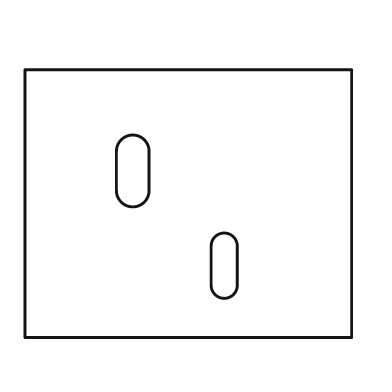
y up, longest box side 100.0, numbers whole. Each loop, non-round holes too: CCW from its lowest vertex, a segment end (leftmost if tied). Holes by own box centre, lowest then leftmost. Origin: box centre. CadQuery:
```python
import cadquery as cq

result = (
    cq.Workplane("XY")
    .moveTo(-50.0, -41.0)
    .lineTo(50.0, -41.0)
    .lineTo(50.0, 41.0)
    .lineTo(-50.0, 41.0)
    .close()
    .moveTo(7.0, -25.0)
    .threePointArc((11.0, -29.0), (15.0, -25.0))
    .lineTo(15.0, -13.0)
    .threePointArc((11.0, -9.0), (7.0, -13.0))
    .close()
    .moveTo(-22.0, 4.0)
    .threePointArc((-17.0, -1.0), (-12.0, 4.0))
    .lineTo(-12.0, 16.0)
    .threePointArc((-17.0, 21.0), (-22.0, 16.0))
    .close()
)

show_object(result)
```